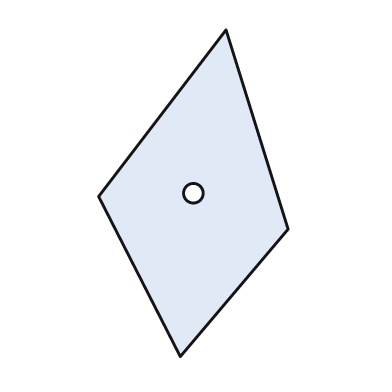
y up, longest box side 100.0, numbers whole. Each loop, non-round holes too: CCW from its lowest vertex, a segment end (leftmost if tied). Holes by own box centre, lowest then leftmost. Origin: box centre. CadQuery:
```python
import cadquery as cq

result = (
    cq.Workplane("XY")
    .moveTo(-4.0, -50.0)
    .lineTo(29.0, -11.0)
    .lineTo(10.0, 50.0)
    .lineTo(-29.0, -1.0)
    .close()
    .moveTo(0.0, 0.0)
    .circle(3.0)
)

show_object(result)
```